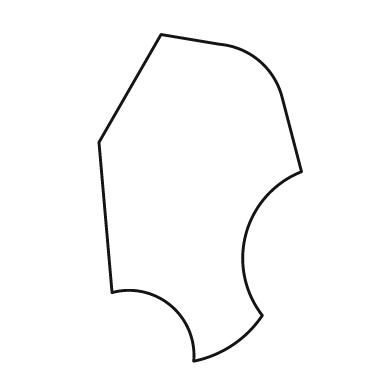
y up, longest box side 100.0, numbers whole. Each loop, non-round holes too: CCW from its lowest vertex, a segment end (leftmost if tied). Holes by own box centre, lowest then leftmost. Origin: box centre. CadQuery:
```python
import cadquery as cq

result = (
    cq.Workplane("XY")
    .moveTo(-2.0, -50.0)
    .threePointArc((10.0, -45.0), (19.0, -36.0))
    .threePointArc((14.0, -11.0), (31.0, 8.0))
    .lineTo(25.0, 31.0)
    .threePointArc((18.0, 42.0), (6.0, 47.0))
    .lineTo(-12.0, 50.0)
    .lineTo(-31.0, 17.0)
    .lineTo(-27.0, -29.0)
    .threePointArc((-9.0, -33.0), (-2.0, -50.0))
    .close()
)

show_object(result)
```